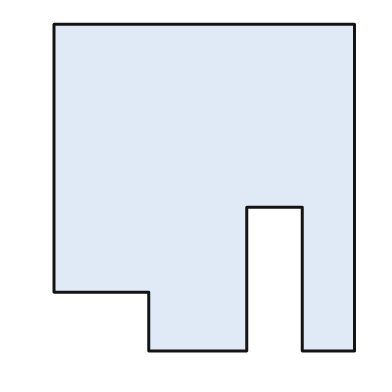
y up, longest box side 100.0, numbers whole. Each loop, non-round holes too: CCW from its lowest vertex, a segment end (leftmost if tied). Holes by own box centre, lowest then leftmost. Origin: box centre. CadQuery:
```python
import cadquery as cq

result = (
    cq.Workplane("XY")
    .moveTo(-17.0, -50.0)
    .lineTo(13.0, -50.0)
    .lineTo(13.0, -6.0)
    .lineTo(30.0, -6.0)
    .lineTo(30.0, -50.0)
    .lineTo(46.0, -50.0)
    .lineTo(46.0, 50.0)
    .lineTo(-46.0, 50.0)
    .lineTo(-46.0, -32.0)
    .lineTo(-17.0, -32.0)
    .close()
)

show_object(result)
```